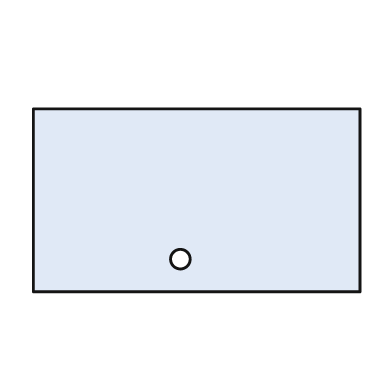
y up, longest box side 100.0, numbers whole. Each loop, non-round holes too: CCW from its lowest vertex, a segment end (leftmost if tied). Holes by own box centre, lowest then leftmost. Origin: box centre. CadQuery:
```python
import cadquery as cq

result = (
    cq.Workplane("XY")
    .moveTo(-50.0, -28.0)
    .lineTo(50.0, -28.0)
    .lineTo(50.0, 28.0)
    .lineTo(-50.0, 28.0)
    .close()
    .moveTo(-5.0, -18.0)
    .circle(3.0)
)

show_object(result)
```